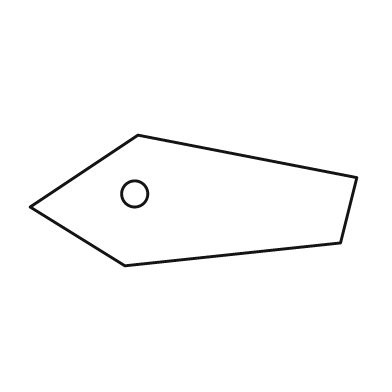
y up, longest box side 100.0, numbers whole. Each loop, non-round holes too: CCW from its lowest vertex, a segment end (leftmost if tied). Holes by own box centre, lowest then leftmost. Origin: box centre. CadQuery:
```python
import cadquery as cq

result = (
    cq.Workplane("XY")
    .moveTo(-21.0, -20.0)
    .lineTo(45.0, -13.0)
    .lineTo(50.0, 7.0)
    .lineTo(-17.0, 20.0)
    .lineTo(-50.0, -2.0)
    .close()
    .moveTo(-18.0, 2.0)
    .circle(4.0)
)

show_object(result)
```